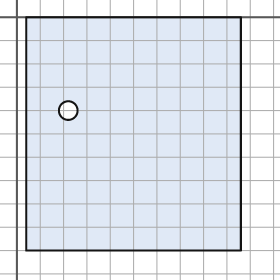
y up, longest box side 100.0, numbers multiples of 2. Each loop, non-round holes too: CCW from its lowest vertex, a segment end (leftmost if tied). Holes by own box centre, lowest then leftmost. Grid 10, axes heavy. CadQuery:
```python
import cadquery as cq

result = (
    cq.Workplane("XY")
    .moveTo(4.0, -100.0)
    .lineTo(96.0, -100.0)
    .lineTo(96.0, 0.0)
    .lineTo(4.0, 0.0)
    .close()
    .moveTo(22.0, -40.0)
    .circle(4.0)
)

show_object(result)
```